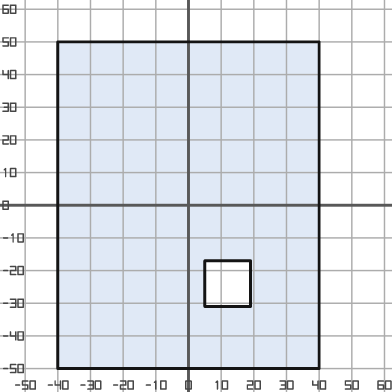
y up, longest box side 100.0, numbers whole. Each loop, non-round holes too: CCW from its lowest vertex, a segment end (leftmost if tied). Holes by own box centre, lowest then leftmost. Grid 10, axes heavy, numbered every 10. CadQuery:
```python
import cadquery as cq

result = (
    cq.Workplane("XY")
    .moveTo(-40.0, -50.0)
    .lineTo(40.0, -50.0)
    .lineTo(40.0, 50.0)
    .lineTo(-40.0, 50.0)
    .close()
    .moveTo(5.0, -31.0)
    .lineTo(19.0, -31.0)
    .lineTo(19.0, -17.0)
    .lineTo(5.0, -17.0)
    .close()
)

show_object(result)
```